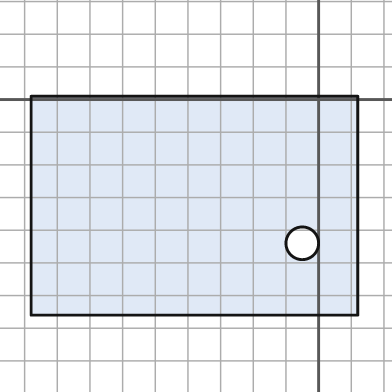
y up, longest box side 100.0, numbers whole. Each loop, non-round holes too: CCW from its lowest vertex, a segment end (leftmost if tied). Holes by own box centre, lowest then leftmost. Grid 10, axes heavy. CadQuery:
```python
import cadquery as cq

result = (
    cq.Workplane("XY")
    .moveTo(-88.0, -66.0)
    .lineTo(12.0, -66.0)
    .lineTo(12.0, 1.0)
    .lineTo(-88.0, 1.0)
    .close()
    .moveTo(-5.0, -44.0)
    .circle(5.0)
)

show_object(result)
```